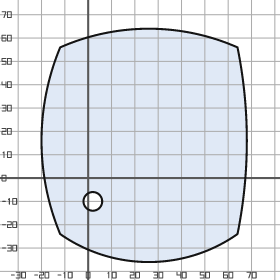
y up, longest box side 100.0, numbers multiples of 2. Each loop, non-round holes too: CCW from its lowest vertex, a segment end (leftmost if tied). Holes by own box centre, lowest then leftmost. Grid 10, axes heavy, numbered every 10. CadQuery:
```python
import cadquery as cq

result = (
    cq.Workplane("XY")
    .moveTo(-12.0, -24.0)
    .threePointArc((26.0, -36.0), (64.0, -24.0))
    .threePointArc((68.0, 16.0), (64.0, 56.0))
    .threePointArc((26.0, 64.0), (-12.0, 56.0))
    .threePointArc((-20.0, 16.0), (-12.0, -24.0))
    .close()
    .moveTo(2.0, -10.0)
    .circle(4.0)
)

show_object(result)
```